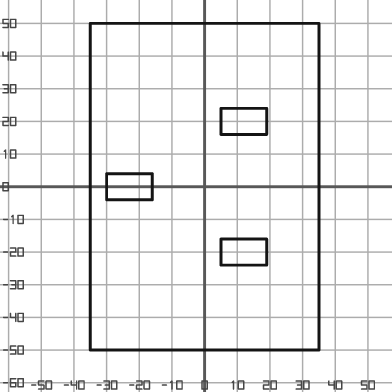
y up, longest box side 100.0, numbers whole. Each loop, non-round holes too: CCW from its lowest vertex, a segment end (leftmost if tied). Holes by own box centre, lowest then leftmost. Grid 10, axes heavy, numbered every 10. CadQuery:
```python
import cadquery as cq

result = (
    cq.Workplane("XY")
    .moveTo(-35.0, -50.0)
    .lineTo(35.0, -50.0)
    .lineTo(35.0, 50.0)
    .lineTo(-35.0, 50.0)
    .close()
    .moveTo(5.0, -24.0)
    .lineTo(19.0, -24.0)
    .lineTo(19.0, -16.0)
    .lineTo(5.0, -16.0)
    .close()
    .moveTo(-30.0, -4.0)
    .lineTo(-16.0, -4.0)
    .lineTo(-16.0, 4.0)
    .lineTo(-30.0, 4.0)
    .close()
    .moveTo(5.0, 16.0)
    .lineTo(19.0, 16.0)
    .lineTo(19.0, 24.0)
    .lineTo(5.0, 24.0)
    .close()
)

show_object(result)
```